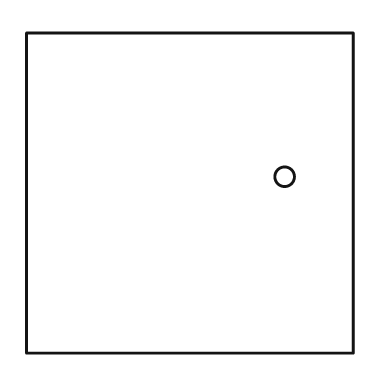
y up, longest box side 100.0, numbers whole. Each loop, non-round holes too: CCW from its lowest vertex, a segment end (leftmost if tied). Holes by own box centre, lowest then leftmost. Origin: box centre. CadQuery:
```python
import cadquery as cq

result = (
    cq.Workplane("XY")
    .moveTo(-50.0, -49.0)
    .lineTo(50.0, -49.0)
    .lineTo(50.0, 49.0)
    .lineTo(-50.0, 49.0)
    .close()
    .moveTo(29.0, 5.0)
    .circle(3.0)
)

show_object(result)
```